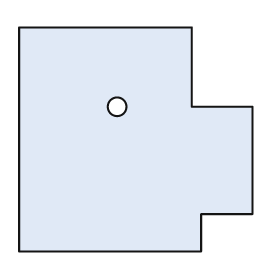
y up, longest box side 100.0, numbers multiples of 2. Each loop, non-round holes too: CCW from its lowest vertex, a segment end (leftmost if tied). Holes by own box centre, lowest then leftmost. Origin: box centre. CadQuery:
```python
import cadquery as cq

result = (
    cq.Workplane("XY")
    .moveTo(-50.0, -48.0)
    .lineTo(28.0, -48.0)
    .lineTo(28.0, -32.0)
    .lineTo(50.0, -32.0)
    .lineTo(50.0, 14.0)
    .lineTo(24.0, 14.0)
    .lineTo(24.0, 48.0)
    .lineTo(-50.0, 48.0)
    .close()
    .moveTo(-8.0, 14.0)
    .circle(4.0)
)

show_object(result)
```